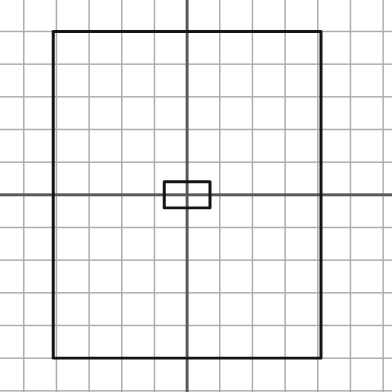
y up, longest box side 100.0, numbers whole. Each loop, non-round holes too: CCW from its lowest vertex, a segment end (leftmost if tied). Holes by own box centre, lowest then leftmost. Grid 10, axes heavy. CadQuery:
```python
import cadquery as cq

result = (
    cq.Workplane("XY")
    .moveTo(-41.0, -50.0)
    .lineTo(41.0, -50.0)
    .lineTo(41.0, 50.0)
    .lineTo(-41.0, 50.0)
    .close()
    .moveTo(-7.0, -4.0)
    .lineTo(7.0, -4.0)
    .lineTo(7.0, 4.0)
    .lineTo(-7.0, 4.0)
    .close()
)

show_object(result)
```